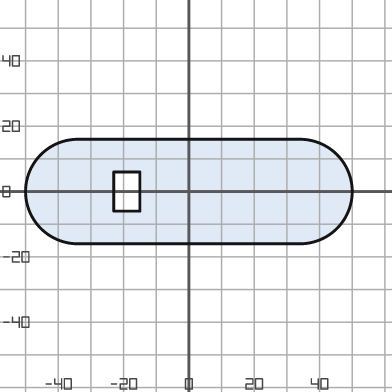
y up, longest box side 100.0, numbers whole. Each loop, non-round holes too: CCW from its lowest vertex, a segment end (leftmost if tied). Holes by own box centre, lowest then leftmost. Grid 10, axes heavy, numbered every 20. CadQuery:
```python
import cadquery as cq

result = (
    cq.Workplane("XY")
    .moveTo(-34.0, -16.0)
    .lineTo(34.0, -16.0)
    .threePointArc((50.0, 0.0), (34.0, 16.0))
    .lineTo(-34.0, 16.0)
    .threePointArc((-50.0, 0.0), (-34.0, -16.0))
    .close()
    .moveTo(-23.0, -6.0)
    .lineTo(-15.0, -6.0)
    .lineTo(-15.0, 6.0)
    .lineTo(-23.0, 6.0)
    .close()
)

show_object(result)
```